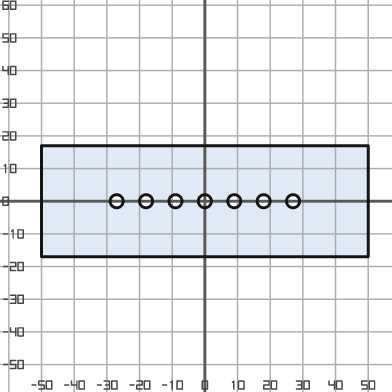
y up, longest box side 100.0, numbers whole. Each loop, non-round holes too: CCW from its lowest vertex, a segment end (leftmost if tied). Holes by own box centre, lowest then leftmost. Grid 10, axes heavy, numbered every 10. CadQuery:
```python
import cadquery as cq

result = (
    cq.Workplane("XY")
    .moveTo(-50.0, -17.0)
    .lineTo(50.0, -17.0)
    .lineTo(50.0, 17.0)
    .lineTo(-50.0, 17.0)
    .close()
    .moveTo(-27.0, 0.0)
    .circle(2.0)
    .moveTo(-18.0, 0.0)
    .circle(2.0)
    .moveTo(-9.0, 0.0)
    .circle(2.0)
    .moveTo(0.0, 0.0)
    .circle(2.0)
    .moveTo(9.0, 0.0)
    .circle(2.0)
    .moveTo(18.0, 0.0)
    .circle(2.0)
    .moveTo(27.0, 0.0)
    .circle(2.0)
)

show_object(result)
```